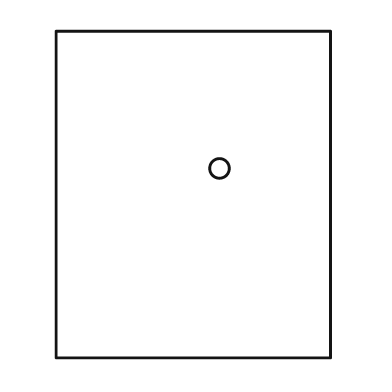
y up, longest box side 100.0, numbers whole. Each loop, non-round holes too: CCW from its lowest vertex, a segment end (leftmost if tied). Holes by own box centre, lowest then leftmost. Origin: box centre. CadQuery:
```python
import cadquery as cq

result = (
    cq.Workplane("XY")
    .moveTo(-42.0, -50.0)
    .lineTo(42.0, -50.0)
    .lineTo(42.0, 50.0)
    .lineTo(-42.0, 50.0)
    .close()
    .moveTo(8.0, 8.0)
    .circle(3.0)
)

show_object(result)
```